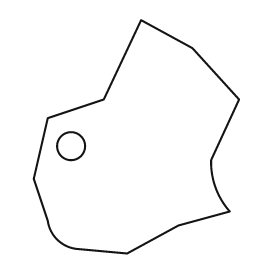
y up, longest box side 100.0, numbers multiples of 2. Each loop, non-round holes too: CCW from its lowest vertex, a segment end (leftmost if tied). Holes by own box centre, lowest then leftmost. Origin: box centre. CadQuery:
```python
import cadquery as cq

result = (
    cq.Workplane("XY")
    .moveTo(-4.0, -50.0)
    .lineTo(18.0, -38.0)
    .lineTo(40.0, -32.0)
    .threePointArc((34.0, -22.0), (32.0, -10.0))
    .lineTo(44.0, 16.0)
    .lineTo(24.0, 38.0)
    .lineTo(2.0, 50.0)
    .lineTo(-14.0, 16.0)
    .lineTo(-38.0, 8.0)
    .lineTo(-44.0, -18.0)
    .lineTo(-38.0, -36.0)
    .threePointArc((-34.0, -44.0), (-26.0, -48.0))
    .close()
    .moveTo(-28.0, -4.0)
    .circle(6.0)
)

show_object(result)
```